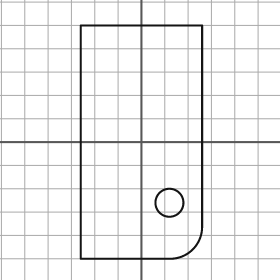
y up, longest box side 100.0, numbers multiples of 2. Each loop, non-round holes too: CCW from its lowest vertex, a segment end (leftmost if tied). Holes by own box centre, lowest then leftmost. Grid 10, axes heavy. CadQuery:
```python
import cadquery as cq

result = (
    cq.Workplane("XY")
    .moveTo(-26.0, -50.0)
    .lineTo(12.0, -50.0)
    .threePointArc((22.0, -46.0), (26.0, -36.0))
    .lineTo(26.0, 50.0)
    .lineTo(-26.0, 50.0)
    .close()
    .moveTo(12.0, -26.0)
    .circle(6.0)
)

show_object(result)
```